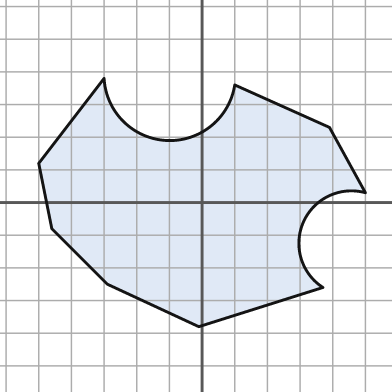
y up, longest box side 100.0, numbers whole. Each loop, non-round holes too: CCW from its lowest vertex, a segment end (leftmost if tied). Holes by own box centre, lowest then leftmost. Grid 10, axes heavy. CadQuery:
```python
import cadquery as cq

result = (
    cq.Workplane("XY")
    .moveTo(-1.0, -38.0)
    .lineTo(37.0, -26.0)
    .threePointArc((31.0, -6.0), (50.0, 3.0))
    .lineTo(39.0, 23.0)
    .lineTo(10.0, 36.0)
    .threePointArc((-11.0, 19.0), (-30.0, 38.0))
    .lineTo(-50.0, 12.0)
    .lineTo(-46.0, -8.0)
    .lineTo(-29.0, -25.0)
    .close()
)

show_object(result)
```